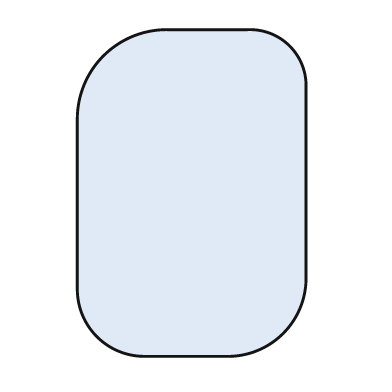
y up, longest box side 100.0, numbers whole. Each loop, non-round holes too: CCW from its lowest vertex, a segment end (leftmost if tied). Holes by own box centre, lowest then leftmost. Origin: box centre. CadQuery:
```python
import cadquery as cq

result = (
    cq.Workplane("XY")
    .moveTo(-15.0, -50.0)
    .lineTo(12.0, -50.0)
    .threePointArc((28.0, -43.0), (35.0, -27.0))
    .lineTo(35.0, 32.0)
    .threePointArc((30.0, 45.0), (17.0, 50.0))
    .lineTo(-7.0, 50.0)
    .threePointArc((-27.0, 42.0), (-35.0, 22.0))
    .lineTo(-35.0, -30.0)
    .threePointArc((-29.0, -44.0), (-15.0, -50.0))
    .close()
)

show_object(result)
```